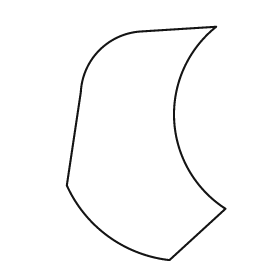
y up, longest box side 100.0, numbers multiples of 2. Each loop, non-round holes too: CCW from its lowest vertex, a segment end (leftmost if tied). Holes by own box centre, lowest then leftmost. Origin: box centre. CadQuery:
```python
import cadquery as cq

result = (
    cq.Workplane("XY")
    .moveTo(10.0, -50.0)
    .lineTo(34.0, -28.0)
    .threePointArc((12.0, 10.0), (30.0, 50.0))
    .lineTo(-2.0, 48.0)
    .threePointArc((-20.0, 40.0), (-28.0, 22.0))
    .lineTo(-34.0, -18.0)
    .threePointArc((-16.0, -40.0), (10.0, -50.0))
    .close()
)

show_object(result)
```